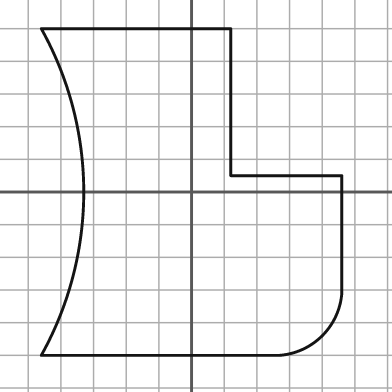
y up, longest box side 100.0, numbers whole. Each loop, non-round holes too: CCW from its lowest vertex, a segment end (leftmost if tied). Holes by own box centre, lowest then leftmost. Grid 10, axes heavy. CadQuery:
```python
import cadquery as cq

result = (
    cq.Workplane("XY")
    .moveTo(-46.0, -50.0)
    .lineTo(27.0, -50.0)
    .threePointArc((40.0, -44.0), (46.0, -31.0))
    .lineTo(46.0, 5.0)
    .lineTo(12.0, 5.0)
    .lineTo(12.0, 50.0)
    .lineTo(-46.0, 50.0)
    .threePointArc((-33.0, 0.0), (-46.0, -50.0))
    .close()
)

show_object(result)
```